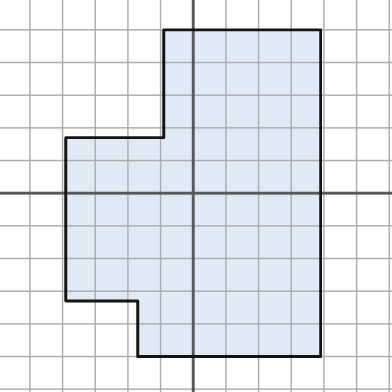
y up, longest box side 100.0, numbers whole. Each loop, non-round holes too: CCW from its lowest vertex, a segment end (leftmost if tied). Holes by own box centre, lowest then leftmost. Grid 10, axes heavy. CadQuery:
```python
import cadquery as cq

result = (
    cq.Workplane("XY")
    .moveTo(-17.0, -50.0)
    .lineTo(39.0, -50.0)
    .lineTo(39.0, 50.0)
    .lineTo(-9.0, 50.0)
    .lineTo(-9.0, 17.0)
    .lineTo(-39.0, 17.0)
    .lineTo(-39.0, -33.0)
    .lineTo(-17.0, -33.0)
    .close()
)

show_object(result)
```